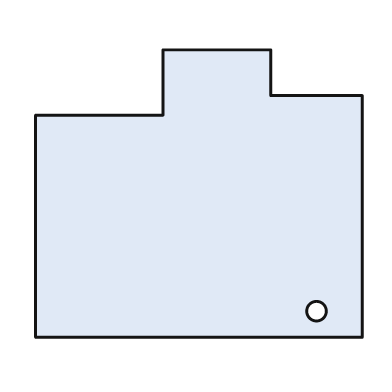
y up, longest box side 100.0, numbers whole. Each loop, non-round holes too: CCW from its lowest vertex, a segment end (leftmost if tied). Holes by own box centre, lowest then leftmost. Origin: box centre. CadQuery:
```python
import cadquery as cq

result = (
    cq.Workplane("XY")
    .moveTo(-50.0, -44.0)
    .lineTo(50.0, -44.0)
    .lineTo(50.0, 30.0)
    .lineTo(22.0, 30.0)
    .lineTo(22.0, 44.0)
    .lineTo(-11.0, 44.0)
    .lineTo(-11.0, 24.0)
    .lineTo(-50.0, 24.0)
    .close()
    .moveTo(36.0, -36.0)
    .circle(3.0)
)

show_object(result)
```